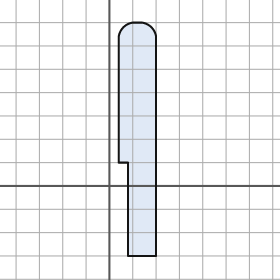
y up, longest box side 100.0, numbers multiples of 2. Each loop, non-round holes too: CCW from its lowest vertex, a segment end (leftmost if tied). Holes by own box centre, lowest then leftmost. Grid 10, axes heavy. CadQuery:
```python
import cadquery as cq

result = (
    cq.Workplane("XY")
    .moveTo(8.0, -30.0)
    .lineTo(20.0, -30.0)
    .lineTo(20.0, 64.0)
    .threePointArc((18.0, 68.0), (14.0, 70.0))
    .lineTo(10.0, 70.0)
    .threePointArc((6.0, 68.0), (4.0, 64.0))
    .lineTo(4.0, 10.0)
    .lineTo(8.0, 10.0)
    .close()
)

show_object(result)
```